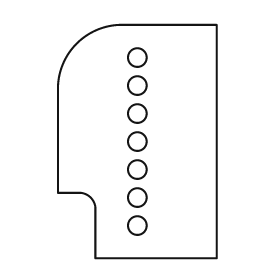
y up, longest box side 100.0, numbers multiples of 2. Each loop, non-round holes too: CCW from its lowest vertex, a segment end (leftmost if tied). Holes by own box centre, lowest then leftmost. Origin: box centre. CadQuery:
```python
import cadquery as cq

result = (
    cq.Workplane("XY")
    .moveTo(-18.0, -50.0)
    .lineTo(34.0, -50.0)
    .lineTo(34.0, 50.0)
    .lineTo(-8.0, 50.0)
    .threePointArc((-26.0, 42.0), (-34.0, 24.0))
    .lineTo(-34.0, -22.0)
    .lineTo(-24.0, -22.0)
    .threePointArc((-20.0, -24.0), (-18.0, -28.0))
    .close()
    .moveTo(0.0, -36.0)
    .circle(4.0)
    .moveTo(0.0, -24.0)
    .circle(4.0)
    .moveTo(0.0, -12.0)
    .circle(4.0)
    .moveTo(0.0, 0.0)
    .circle(4.0)
    .moveTo(0.0, 12.0)
    .circle(4.0)
    .moveTo(0.0, 24.0)
    .circle(4.0)
    .moveTo(0.0, 36.0)
    .circle(4.0)
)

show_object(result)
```